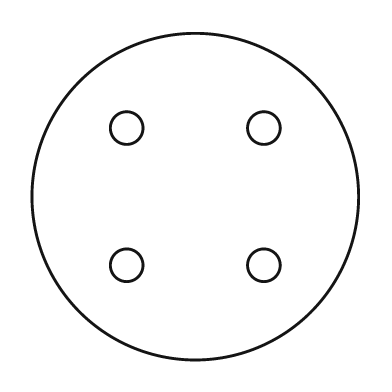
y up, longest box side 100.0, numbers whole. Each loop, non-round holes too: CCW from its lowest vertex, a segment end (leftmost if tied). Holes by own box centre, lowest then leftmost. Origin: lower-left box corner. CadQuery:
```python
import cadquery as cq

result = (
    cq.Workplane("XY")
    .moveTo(50.0, 50.0)
    .circle(50.0)
    .moveTo(29.0, 29.0)
    .circle(5.0)
    .moveTo(71.0, 29.0)
    .circle(5.0)
    .moveTo(29.0, 71.0)
    .circle(5.0)
    .moveTo(71.0, 71.0)
    .circle(5.0)
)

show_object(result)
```